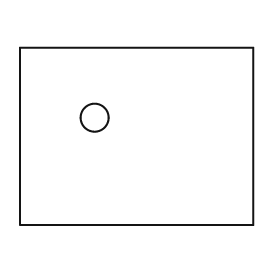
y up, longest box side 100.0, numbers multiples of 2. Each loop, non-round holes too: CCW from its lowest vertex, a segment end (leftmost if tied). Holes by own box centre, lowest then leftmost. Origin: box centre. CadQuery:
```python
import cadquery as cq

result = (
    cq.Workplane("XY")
    .moveTo(-50.0, -38.0)
    .lineTo(50.0, -38.0)
    .lineTo(50.0, 38.0)
    .lineTo(-50.0, 38.0)
    .close()
    .moveTo(-18.0, 8.0)
    .circle(6.0)
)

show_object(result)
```